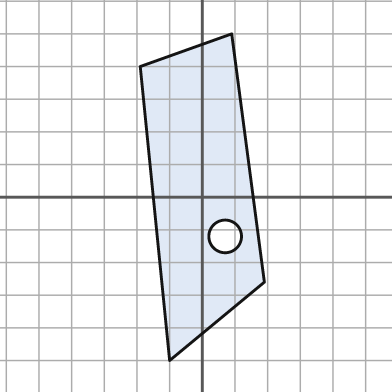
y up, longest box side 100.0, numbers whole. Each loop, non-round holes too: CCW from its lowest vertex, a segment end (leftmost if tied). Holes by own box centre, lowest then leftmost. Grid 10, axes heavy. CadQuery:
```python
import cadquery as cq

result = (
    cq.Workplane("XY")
    .moveTo(-10.0, -50.0)
    .lineTo(19.0, -26.0)
    .lineTo(9.0, 50.0)
    .lineTo(-19.0, 40.0)
    .close()
    .moveTo(7.0, -12.0)
    .circle(5.0)
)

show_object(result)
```